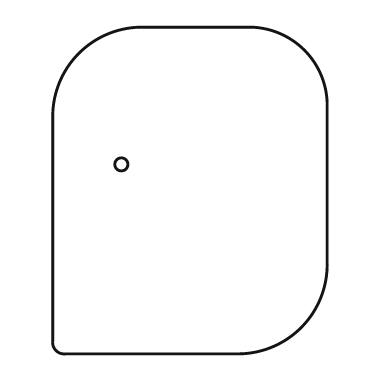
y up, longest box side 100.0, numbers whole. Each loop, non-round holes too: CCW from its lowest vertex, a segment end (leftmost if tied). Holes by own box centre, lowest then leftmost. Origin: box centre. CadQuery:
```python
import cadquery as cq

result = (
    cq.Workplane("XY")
    .moveTo(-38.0, -50.0)
    .lineTo(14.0, -50.0)
    .threePointArc((34.0, -42.0), (42.0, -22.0))
    .lineTo(42.0, 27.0)
    .threePointArc((35.0, 43.0), (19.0, 50.0))
    .lineTo(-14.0, 50.0)
    .threePointArc((-34.0, 42.0), (-42.0, 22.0))
    .lineTo(-42.0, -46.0)
    .threePointArc((-41.0, -49.0), (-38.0, -50.0))
    .close()
    .moveTo(-21.0, 8.0)
    .circle(2.0)
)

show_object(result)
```